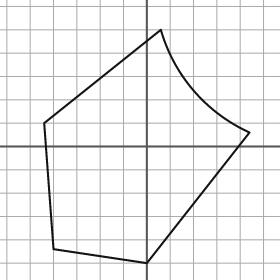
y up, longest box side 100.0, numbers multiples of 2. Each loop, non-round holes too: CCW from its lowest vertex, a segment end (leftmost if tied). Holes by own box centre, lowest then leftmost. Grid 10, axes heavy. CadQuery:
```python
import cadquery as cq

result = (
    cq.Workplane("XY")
    .moveTo(0.0, -50.0)
    .lineTo(44.0, 6.0)
    .threePointArc((20.0, 24.0), (6.0, 50.0))
    .lineTo(-44.0, 10.0)
    .lineTo(-40.0, -44.0)
    .close()
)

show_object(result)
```